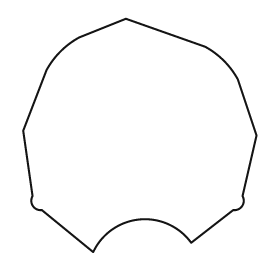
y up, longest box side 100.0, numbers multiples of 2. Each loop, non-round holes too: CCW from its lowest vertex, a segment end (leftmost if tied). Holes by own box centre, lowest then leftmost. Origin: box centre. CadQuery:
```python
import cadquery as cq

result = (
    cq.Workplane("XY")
    .moveTo(-20.0, -50.0)
    .threePointArc((0.0, -36.0), (22.0, -46.0))
    .lineTo(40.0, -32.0)
    .threePointArc((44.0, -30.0), (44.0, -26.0))
    .lineTo(50.0, 0.0)
    .lineTo(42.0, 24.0)
    .threePointArc((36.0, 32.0), (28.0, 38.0))
    .lineTo(-6.0, 50.0)
    .lineTo(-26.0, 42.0)
    .threePointArc((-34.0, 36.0), (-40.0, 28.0))
    .lineTo(-50.0, 2.0)
    .lineTo(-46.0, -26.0)
    .threePointArc((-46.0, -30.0), (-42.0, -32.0))
    .close()
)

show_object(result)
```